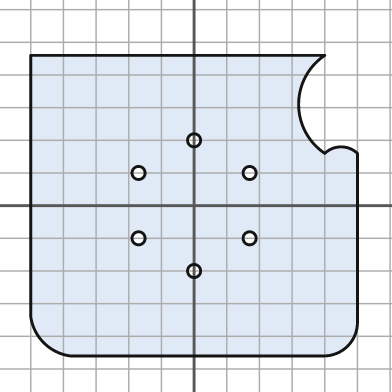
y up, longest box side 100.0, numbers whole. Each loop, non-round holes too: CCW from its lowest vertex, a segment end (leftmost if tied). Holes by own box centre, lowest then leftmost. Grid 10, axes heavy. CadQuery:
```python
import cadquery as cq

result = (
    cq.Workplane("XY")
    .moveTo(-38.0, -46.0)
    .lineTo(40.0, -46.0)
    .threePointArc((47.0, -43.0), (50.0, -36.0))
    .lineTo(50.0, 16.0)
    .threePointArc((45.0, 18.0), (40.0, 16.0))
    .threePointArc((32.0, 31.0), (40.0, 46.0))
    .lineTo(-50.0, 46.0)
    .lineTo(-50.0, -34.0)
    .threePointArc((-46.0, -42.0), (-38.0, -46.0))
    .close()
    .moveTo(0.0, -20.0)
    .circle(2.0)
    .moveTo(-17.0, -10.0)
    .circle(2.0)
    .moveTo(17.0, -10.0)
    .circle(2.0)
    .moveTo(-17.0, 10.0)
    .circle(2.0)
    .moveTo(17.0, 10.0)
    .circle(2.0)
    .moveTo(0.0, 20.0)
    .circle(2.0)
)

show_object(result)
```